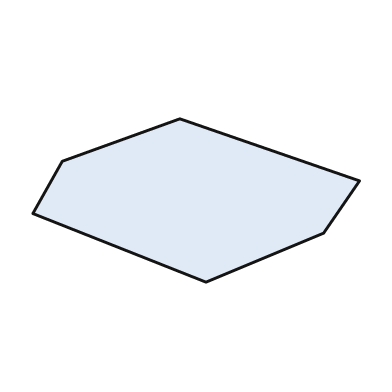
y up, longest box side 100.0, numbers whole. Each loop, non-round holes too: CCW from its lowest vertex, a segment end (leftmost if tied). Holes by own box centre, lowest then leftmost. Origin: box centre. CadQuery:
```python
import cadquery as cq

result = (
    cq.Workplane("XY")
    .moveTo(3.0, -25.0)
    .lineTo(39.0, -10.0)
    .lineTo(50.0, 6.0)
    .lineTo(-5.0, 25.0)
    .lineTo(-41.0, 12.0)
    .lineTo(-50.0, -4.0)
    .close()
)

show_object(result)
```